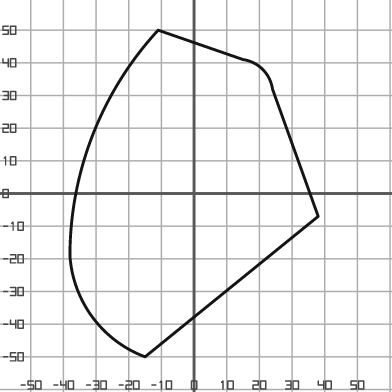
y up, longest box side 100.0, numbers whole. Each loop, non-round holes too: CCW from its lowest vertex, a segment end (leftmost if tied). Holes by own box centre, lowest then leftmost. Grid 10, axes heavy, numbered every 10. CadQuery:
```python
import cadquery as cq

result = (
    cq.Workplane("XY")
    .moveTo(-15.0, -50.0)
    .lineTo(38.0, -7.0)
    .lineTo(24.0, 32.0)
    .threePointArc((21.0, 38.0), (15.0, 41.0))
    .lineTo(-11.0, 50.0)
    .threePointArc((-31.0, 18.0), (-38.0, -19.0))
    .threePointArc((-31.0, -38.0), (-15.0, -50.0))
    .close()
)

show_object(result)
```